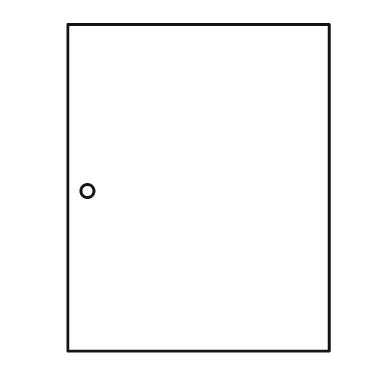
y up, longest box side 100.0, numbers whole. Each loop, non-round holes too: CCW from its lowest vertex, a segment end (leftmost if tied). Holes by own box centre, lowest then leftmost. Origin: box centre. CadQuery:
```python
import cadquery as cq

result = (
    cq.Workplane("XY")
    .moveTo(-40.0, -50.0)
    .lineTo(40.0, -50.0)
    .lineTo(40.0, 50.0)
    .lineTo(-40.0, 50.0)
    .close()
    .moveTo(-34.0, -1.0)
    .circle(2.0)
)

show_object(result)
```